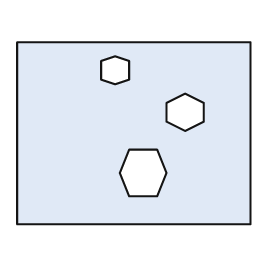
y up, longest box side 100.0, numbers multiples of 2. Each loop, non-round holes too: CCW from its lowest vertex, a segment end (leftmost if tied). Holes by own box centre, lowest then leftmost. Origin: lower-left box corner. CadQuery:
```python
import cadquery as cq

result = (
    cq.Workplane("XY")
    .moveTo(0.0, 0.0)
    .lineTo(100.0, 0.0)
    .lineTo(100.0, 78.0)
    .lineTo(0.0, 78.0)
    .close()
    .moveTo(48.0, 12.0)
    .lineTo(60.0, 12.0)
    .lineTo(64.0, 22.0)
    .lineTo(60.0, 32.0)
    .lineTo(48.0, 32.0)
    .lineTo(44.0, 22.0)
    .close()
    .moveTo(72.0, 40.0)
    .lineTo(80.0, 44.0)
    .lineTo(80.0, 52.0)
    .lineTo(72.0, 56.0)
    .lineTo(64.0, 52.0)
    .lineTo(64.0, 44.0)
    .close()
    .moveTo(42.0, 60.0)
    .lineTo(48.0, 62.0)
    .lineTo(48.0, 70.0)
    .lineTo(42.0, 72.0)
    .lineTo(36.0, 70.0)
    .lineTo(36.0, 62.0)
    .close()
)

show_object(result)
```